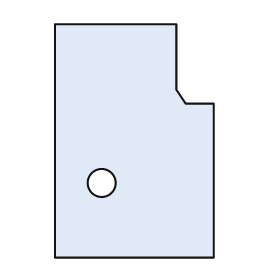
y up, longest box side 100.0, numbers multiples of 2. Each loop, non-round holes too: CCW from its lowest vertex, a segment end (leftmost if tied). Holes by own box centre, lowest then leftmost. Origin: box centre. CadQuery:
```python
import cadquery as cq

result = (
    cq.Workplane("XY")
    .moveTo(-34.0, -50.0)
    .lineTo(34.0, -50.0)
    .lineTo(34.0, 16.0)
    .lineTo(22.0, 16.0)
    .lineTo(18.0, 22.0)
    .lineTo(18.0, 50.0)
    .lineTo(-34.0, 50.0)
    .close()
    .moveTo(-14.0, -18.0)
    .circle(6.0)
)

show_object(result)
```